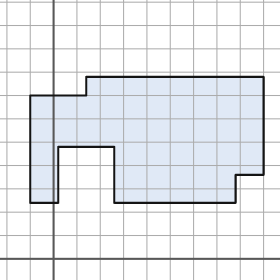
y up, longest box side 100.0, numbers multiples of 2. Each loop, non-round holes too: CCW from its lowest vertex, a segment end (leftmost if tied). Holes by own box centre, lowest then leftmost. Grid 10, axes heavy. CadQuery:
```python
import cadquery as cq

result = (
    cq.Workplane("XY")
    .moveTo(-10.0, 24.0)
    .lineTo(2.0, 24.0)
    .lineTo(2.0, 48.0)
    .lineTo(26.0, 48.0)
    .lineTo(26.0, 24.0)
    .lineTo(78.0, 24.0)
    .lineTo(78.0, 36.0)
    .lineTo(90.0, 36.0)
    .lineTo(90.0, 78.0)
    .lineTo(14.0, 78.0)
    .lineTo(14.0, 70.0)
    .lineTo(-10.0, 70.0)
    .close()
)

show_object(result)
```